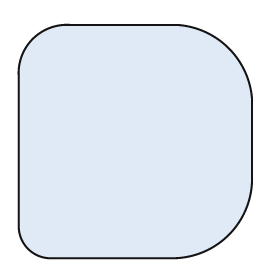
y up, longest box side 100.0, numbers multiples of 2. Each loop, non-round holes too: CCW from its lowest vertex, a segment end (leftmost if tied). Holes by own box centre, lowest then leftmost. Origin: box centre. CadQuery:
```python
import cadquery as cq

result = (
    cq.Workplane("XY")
    .moveTo(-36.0, -50.0)
    .lineTo(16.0, -50.0)
    .threePointArc((40.0, -40.0), (50.0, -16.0))
    .lineTo(50.0, 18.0)
    .threePointArc((40.0, 40.0), (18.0, 50.0))
    .lineTo(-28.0, 50.0)
    .threePointArc((-44.0, 44.0), (-50.0, 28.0))
    .lineTo(-50.0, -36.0)
    .threePointArc((-46.0, -46.0), (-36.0, -50.0))
    .close()
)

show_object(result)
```